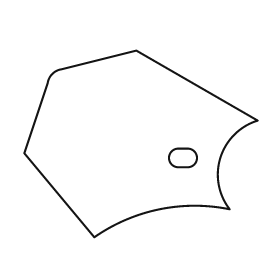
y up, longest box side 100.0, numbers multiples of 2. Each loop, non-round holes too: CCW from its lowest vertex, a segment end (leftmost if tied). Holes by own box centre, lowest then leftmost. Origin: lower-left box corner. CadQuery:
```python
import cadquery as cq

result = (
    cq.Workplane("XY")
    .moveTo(30.0, 0.0)
    .threePointArc((58.0, 12.0), (88.0, 12.0))
    .threePointArc((84.0, 34.0), (100.0, 50.0))
    .lineTo(48.0, 80.0)
    .lineTo(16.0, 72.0)
    .threePointArc((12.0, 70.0), (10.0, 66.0))
    .lineTo(0.0, 36.0)
    .close()
    .moveTo(66.0, 30.0)
    .lineTo(70.0, 30.0)
    .threePointArc((74.0, 34.0), (70.0, 38.0))
    .lineTo(66.0, 38.0)
    .threePointArc((62.0, 34.0), (66.0, 30.0))
    .close()
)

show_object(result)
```